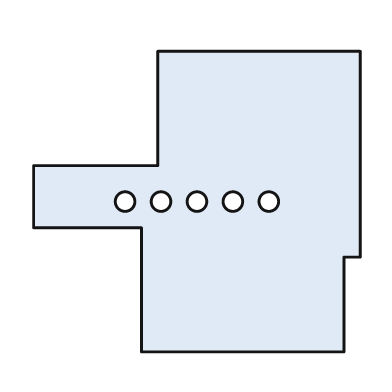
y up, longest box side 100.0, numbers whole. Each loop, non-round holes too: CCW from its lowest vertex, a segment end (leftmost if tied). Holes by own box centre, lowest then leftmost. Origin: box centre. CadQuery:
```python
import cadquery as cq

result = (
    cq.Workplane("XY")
    .moveTo(-17.0, -46.0)
    .lineTo(45.0, -46.0)
    .lineTo(45.0, -17.0)
    .lineTo(50.0, -17.0)
    .lineTo(50.0, 46.0)
    .lineTo(-12.0, 46.0)
    .lineTo(-12.0, 11.0)
    .lineTo(-50.0, 11.0)
    .lineTo(-50.0, -8.0)
    .lineTo(-17.0, -8.0)
    .close()
    .moveTo(-22.0, 0.0)
    .circle(3.0)
    .moveTo(-11.0, 0.0)
    .circle(3.0)
    .moveTo(0.0, 0.0)
    .circle(3.0)
    .moveTo(11.0, 0.0)
    .circle(3.0)
    .moveTo(22.0, 0.0)
    .circle(3.0)
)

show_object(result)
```